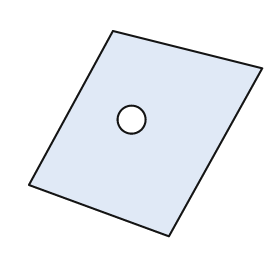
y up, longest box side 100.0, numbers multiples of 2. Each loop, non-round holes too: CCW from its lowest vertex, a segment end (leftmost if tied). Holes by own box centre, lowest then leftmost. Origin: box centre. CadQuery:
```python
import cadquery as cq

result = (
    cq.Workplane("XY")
    .moveTo(10.0, -44.0)
    .lineTo(50.0, 28.0)
    .lineTo(-14.0, 44.0)
    .lineTo(-50.0, -22.0)
    .close()
    .moveTo(-6.0, 6.0)
    .circle(6.0)
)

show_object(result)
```